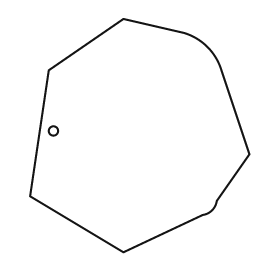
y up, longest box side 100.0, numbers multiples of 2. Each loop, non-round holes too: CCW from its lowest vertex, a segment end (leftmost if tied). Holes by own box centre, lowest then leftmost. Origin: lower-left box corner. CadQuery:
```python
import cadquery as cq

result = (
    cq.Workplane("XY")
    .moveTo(40.0, 0.0)
    .lineTo(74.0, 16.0)
    .threePointArc((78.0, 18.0), (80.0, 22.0))
    .lineTo(94.0, 42.0)
    .lineTo(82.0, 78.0)
    .threePointArc((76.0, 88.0), (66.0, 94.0))
    .lineTo(40.0, 100.0)
    .lineTo(8.0, 78.0)
    .lineTo(0.0, 24.0)
    .close()
    .moveTo(10.0, 52.0)
    .circle(2.0)
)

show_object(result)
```